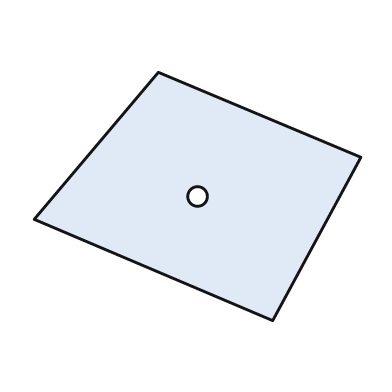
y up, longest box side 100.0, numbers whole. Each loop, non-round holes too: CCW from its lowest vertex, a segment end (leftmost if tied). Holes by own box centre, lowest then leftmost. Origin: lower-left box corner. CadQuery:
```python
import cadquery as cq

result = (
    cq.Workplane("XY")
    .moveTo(73.0, 0.0)
    .lineTo(100.0, 50.0)
    .lineTo(38.0, 76.0)
    .lineTo(0.0, 31.0)
    .close()
    .moveTo(50.0, 38.0)
    .circle(3.0)
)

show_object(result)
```